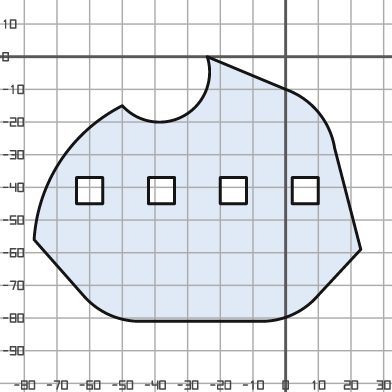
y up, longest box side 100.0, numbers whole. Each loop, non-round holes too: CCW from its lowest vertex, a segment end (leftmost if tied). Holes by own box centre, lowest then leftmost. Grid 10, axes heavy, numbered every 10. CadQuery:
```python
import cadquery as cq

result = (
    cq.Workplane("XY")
    .moveTo(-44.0, -81.0)
    .lineTo(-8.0, -81.0)
    .threePointArc((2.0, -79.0), (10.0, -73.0))
    .lineTo(23.0, -59.0)
    .lineTo(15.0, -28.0)
    .threePointArc((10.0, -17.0), (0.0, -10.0))
    .lineTo(-24.0, 0.0)
    .threePointArc((-31.0, -18.0), (-50.0, -15.0))
    .threePointArc((-69.0, -32.0), (-77.0, -56.0))
    .lineTo(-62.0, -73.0)
    .threePointArc((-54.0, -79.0), (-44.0, -81.0))
    .close()
    .moveTo(-64.0, -45.0)
    .lineTo(-56.0, -45.0)
    .lineTo(-56.0, -37.0)
    .lineTo(-64.0, -37.0)
    .close()
    .moveTo(-42.0, -45.0)
    .lineTo(-34.0, -45.0)
    .lineTo(-34.0, -37.0)
    .lineTo(-42.0, -37.0)
    .close()
    .moveTo(-20.0, -45.0)
    .lineTo(-12.0, -45.0)
    .lineTo(-12.0, -37.0)
    .lineTo(-20.0, -37.0)
    .close()
    .moveTo(2.0, -45.0)
    .lineTo(10.0, -45.0)
    .lineTo(10.0, -37.0)
    .lineTo(2.0, -37.0)
    .close()
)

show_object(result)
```